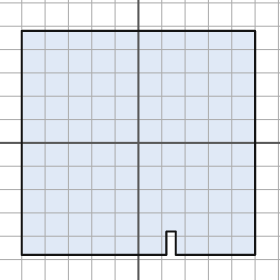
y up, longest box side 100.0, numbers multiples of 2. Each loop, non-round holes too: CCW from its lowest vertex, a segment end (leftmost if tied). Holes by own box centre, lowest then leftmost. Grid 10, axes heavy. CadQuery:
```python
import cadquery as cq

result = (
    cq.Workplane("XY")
    .moveTo(-50.0, -48.0)
    .lineTo(12.0, -48.0)
    .lineTo(12.0, -38.0)
    .lineTo(16.0, -38.0)
    .lineTo(16.0, -48.0)
    .lineTo(50.0, -48.0)
    .lineTo(50.0, 48.0)
    .lineTo(-50.0, 48.0)
    .close()
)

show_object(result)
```